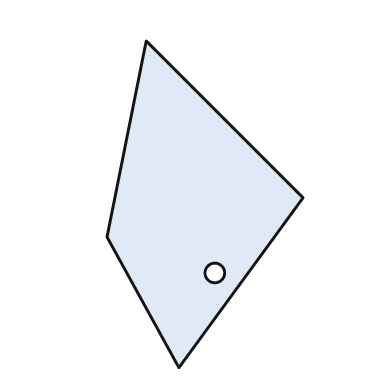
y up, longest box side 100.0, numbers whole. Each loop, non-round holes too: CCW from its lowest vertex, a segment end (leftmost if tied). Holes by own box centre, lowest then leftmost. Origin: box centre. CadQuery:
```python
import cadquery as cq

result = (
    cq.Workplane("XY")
    .moveTo(-8.0, -50.0)
    .lineTo(30.0, 2.0)
    .lineTo(-18.0, 50.0)
    .lineTo(-30.0, -10.0)
    .close()
    .moveTo(3.0, -21.0)
    .circle(3.0)
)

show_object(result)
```